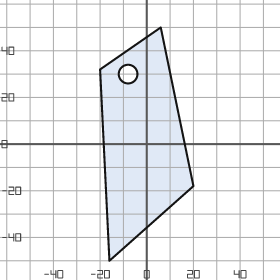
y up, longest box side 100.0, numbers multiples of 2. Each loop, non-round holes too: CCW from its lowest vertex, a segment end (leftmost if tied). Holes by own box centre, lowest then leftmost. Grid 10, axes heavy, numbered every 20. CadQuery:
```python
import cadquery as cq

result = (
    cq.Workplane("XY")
    .moveTo(-16.0, -50.0)
    .lineTo(20.0, -18.0)
    .lineTo(6.0, 50.0)
    .lineTo(-20.0, 32.0)
    .close()
    .moveTo(-8.0, 30.0)
    .circle(4.0)
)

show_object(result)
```